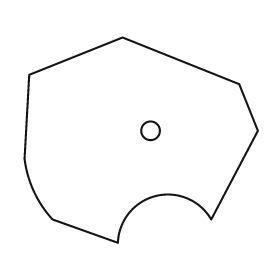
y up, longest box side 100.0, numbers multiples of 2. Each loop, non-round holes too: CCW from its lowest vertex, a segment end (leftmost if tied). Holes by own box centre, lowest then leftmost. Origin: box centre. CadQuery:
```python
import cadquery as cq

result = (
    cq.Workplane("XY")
    .moveTo(-10.0, -44.0)
    .threePointArc((6.0, -24.0), (30.0, -34.0))
    .lineTo(50.0, 4.0)
    .lineTo(42.0, 24.0)
    .lineTo(-8.0, 44.0)
    .lineTo(-48.0, 28.0)
    .lineTo(-50.0, -8.0)
    .threePointArc((-46.0, -22.0), (-38.0, -34.0))
    .close()
    .moveTo(4.0, 4.0)
    .circle(4.0)
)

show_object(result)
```